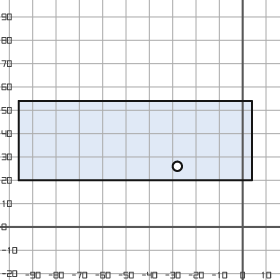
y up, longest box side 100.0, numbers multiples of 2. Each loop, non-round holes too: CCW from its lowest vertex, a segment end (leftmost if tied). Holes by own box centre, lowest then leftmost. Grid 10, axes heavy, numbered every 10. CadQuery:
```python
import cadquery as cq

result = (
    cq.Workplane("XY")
    .moveTo(-96.0, 20.0)
    .lineTo(4.0, 20.0)
    .lineTo(4.0, 54.0)
    .lineTo(-96.0, 54.0)
    .close()
    .moveTo(-28.0, 26.0)
    .circle(2.0)
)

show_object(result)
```